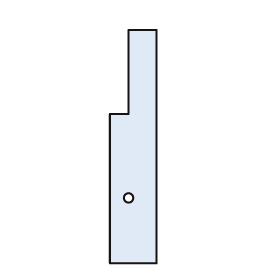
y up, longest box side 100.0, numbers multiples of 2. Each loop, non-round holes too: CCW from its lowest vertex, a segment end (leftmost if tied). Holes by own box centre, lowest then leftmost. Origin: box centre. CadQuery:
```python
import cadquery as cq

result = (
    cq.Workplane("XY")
    .moveTo(-10.0, -50.0)
    .lineTo(10.0, -50.0)
    .lineTo(10.0, 50.0)
    .lineTo(-2.0, 50.0)
    .lineTo(-2.0, 14.0)
    .lineTo(-10.0, 14.0)
    .close()
    .moveTo(-2.0, -22.0)
    .circle(2.0)
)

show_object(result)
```